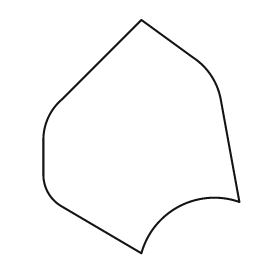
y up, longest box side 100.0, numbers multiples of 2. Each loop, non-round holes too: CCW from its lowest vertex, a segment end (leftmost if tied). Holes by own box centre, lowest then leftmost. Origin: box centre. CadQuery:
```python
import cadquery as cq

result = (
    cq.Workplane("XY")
    .moveTo(0.0, -50.0)
    .threePointArc((16.0, -30.0), (42.0, -28.0))
    .lineTo(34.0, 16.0)
    .threePointArc((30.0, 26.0), (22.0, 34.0))
    .lineTo(0.0, 50.0)
    .lineTo(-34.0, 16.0)
    .threePointArc((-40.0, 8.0), (-42.0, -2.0))
    .lineTo(-42.0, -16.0)
    .threePointArc((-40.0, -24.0), (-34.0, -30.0))
    .close()
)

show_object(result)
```